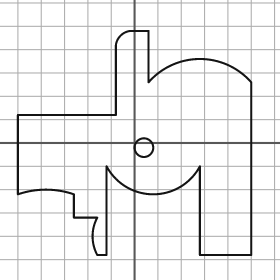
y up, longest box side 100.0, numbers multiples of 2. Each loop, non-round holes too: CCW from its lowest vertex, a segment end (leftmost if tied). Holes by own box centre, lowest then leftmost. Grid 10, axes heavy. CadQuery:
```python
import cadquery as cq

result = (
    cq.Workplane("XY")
    .moveTo(-16.0, -48.0)
    .lineTo(-12.0, -48.0)
    .lineTo(-12.0, -10.0)
    .threePointArc((8.0, -22.0), (28.0, -10.0))
    .lineTo(28.0, -48.0)
    .lineTo(50.0, -48.0)
    .lineTo(50.0, 26.0)
    .threePointArc((28.0, 36.0), (6.0, 26.0))
    .lineTo(6.0, 48.0)
    .lineTo(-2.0, 48.0)
    .threePointArc((-6.0, 46.0), (-8.0, 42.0))
    .lineTo(-8.0, 12.0)
    .lineTo(-50.0, 12.0)
    .lineTo(-50.0, -22.0)
    .threePointArc((-38.0, -20.0), (-26.0, -22.0))
    .lineTo(-26.0, -32.0)
    .lineTo(-16.0, -32.0)
    .threePointArc((-18.0, -40.0), (-16.0, -48.0))
    .close()
    .moveTo(4.0, -2.0)
    .circle(4.0)
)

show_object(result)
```